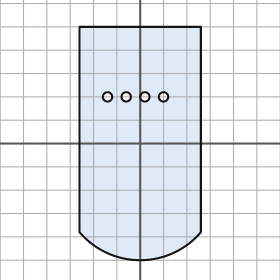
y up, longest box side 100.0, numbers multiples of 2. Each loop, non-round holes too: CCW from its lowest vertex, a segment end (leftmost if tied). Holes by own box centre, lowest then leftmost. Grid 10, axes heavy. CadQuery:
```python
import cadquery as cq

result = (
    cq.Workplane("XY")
    .moveTo(-26.0, -38.0)
    .threePointArc((0.0, -50.0), (26.0, -38.0))
    .lineTo(26.0, 50.0)
    .lineTo(-26.0, 50.0)
    .close()
    .moveTo(-14.0, 20.0)
    .circle(2.0)
    .moveTo(-6.0, 20.0)
    .circle(2.0)
    .moveTo(2.0, 20.0)
    .circle(2.0)
    .moveTo(10.0, 20.0)
    .circle(2.0)
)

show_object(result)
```